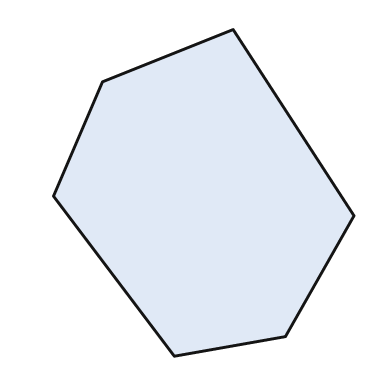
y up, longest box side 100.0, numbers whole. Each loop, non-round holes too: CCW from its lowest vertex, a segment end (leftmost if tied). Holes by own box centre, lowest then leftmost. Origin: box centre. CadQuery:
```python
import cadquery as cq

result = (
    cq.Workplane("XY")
    .moveTo(-9.0, -50.0)
    .lineTo(25.0, -44.0)
    .lineTo(46.0, -7.0)
    .lineTo(9.0, 50.0)
    .lineTo(-31.0, 34.0)
    .lineTo(-46.0, -1.0)
    .close()
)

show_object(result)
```